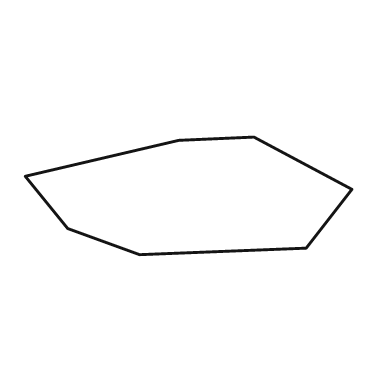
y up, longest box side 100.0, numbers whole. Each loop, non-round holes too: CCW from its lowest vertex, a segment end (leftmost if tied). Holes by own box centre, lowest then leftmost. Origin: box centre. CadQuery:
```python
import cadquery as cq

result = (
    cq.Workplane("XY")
    .moveTo(-15.0, -18.0)
    .lineTo(36.0, -16.0)
    .lineTo(50.0, 2.0)
    .lineTo(20.0, 18.0)
    .lineTo(-3.0, 17.0)
    .lineTo(-50.0, 6.0)
    .lineTo(-37.0, -10.0)
    .close()
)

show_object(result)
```